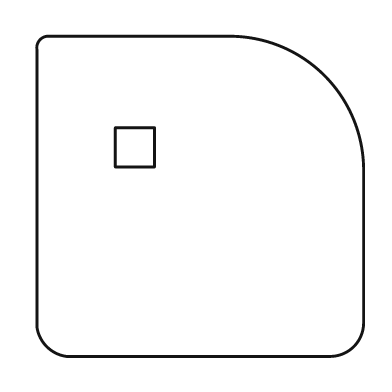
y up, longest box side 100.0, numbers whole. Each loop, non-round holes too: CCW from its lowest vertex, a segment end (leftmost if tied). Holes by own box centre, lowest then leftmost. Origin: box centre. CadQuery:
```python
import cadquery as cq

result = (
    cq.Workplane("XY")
    .moveTo(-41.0, -49.0)
    .lineTo(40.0, -49.0)
    .threePointArc((47.0, -46.0), (50.0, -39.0))
    .lineTo(50.0, 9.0)
    .threePointArc((38.0, 37.0), (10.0, 49.0))
    .lineTo(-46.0, 49.0)
    .threePointArc((-49.0, 48.0), (-50.0, 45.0))
    .lineTo(-50.0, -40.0)
    .threePointArc((-47.0, -46.0), (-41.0, -49.0))
    .close()
    .moveTo(-26.0, 9.0)
    .lineTo(-14.0, 9.0)
    .lineTo(-14.0, 21.0)
    .lineTo(-26.0, 21.0)
    .close()
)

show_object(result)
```